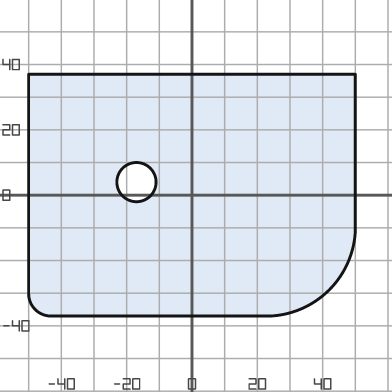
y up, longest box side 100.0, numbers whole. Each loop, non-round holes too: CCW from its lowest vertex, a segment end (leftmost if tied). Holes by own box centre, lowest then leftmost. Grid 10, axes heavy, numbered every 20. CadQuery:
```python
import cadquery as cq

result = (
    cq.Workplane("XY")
    .moveTo(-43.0, -37.0)
    .lineTo(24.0, -37.0)
    .threePointArc((42.0, -29.0), (50.0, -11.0))
    .lineTo(50.0, 37.0)
    .lineTo(-50.0, 37.0)
    .lineTo(-50.0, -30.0)
    .threePointArc((-48.0, -35.0), (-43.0, -37.0))
    .close()
    .moveTo(-17.0, 4.0)
    .circle(6.0)
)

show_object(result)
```